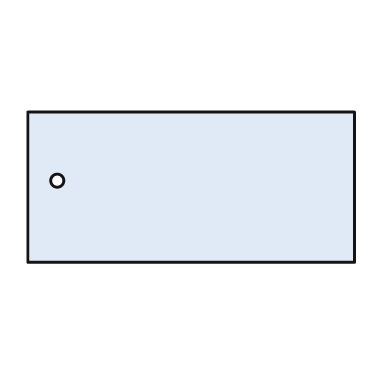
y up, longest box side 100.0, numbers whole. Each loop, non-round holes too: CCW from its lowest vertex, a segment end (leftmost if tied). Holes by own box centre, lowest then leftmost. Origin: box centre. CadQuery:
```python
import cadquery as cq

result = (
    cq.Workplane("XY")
    .moveTo(-50.0, -23.0)
    .lineTo(50.0, -23.0)
    .lineTo(50.0, 23.0)
    .lineTo(-50.0, 23.0)
    .close()
    .moveTo(-41.0, 2.0)
    .circle(2.0)
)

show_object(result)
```